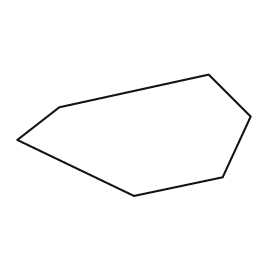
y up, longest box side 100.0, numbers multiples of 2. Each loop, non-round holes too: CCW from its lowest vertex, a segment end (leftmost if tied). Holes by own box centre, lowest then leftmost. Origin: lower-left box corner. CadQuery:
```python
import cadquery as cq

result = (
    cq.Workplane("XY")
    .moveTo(50.0, 0.0)
    .lineTo(88.0, 8.0)
    .lineTo(100.0, 34.0)
    .lineTo(82.0, 52.0)
    .lineTo(18.0, 38.0)
    .lineTo(0.0, 24.0)
    .close()
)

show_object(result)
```